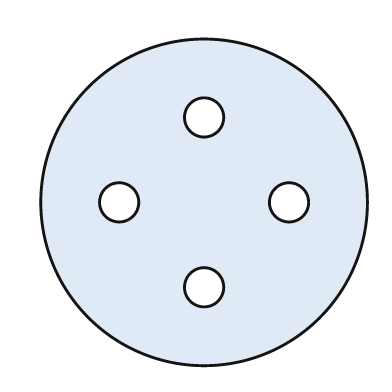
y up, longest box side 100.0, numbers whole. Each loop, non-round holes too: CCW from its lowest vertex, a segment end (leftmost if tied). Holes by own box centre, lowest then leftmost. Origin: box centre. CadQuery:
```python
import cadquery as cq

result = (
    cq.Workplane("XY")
    .moveTo(0.0, 0.0)
    .circle(50.0)
    .moveTo(0.0, -26.0)
    .circle(6.0)
    .moveTo(-26.0, 0.0)
    .circle(6.0)
    .moveTo(26.0, 0.0)
    .circle(6.0)
    .moveTo(0.0, 26.0)
    .circle(6.0)
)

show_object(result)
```